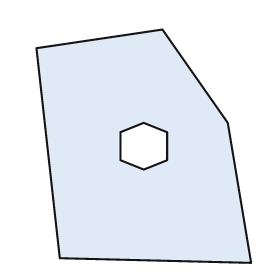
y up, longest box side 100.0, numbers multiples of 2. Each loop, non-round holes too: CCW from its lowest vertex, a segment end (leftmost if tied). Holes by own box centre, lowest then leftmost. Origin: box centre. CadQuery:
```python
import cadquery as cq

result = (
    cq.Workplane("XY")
    .moveTo(46.0, -50.0)
    .lineTo(36.0, 10.0)
    .lineTo(8.0, 50.0)
    .lineTo(-46.0, 42.0)
    .lineTo(-36.0, -48.0)
    .close()
    .moveTo(0.0, -10.0)
    .lineTo(10.0, -6.0)
    .lineTo(10.0, 6.0)
    .lineTo(0.0, 10.0)
    .lineTo(-10.0, 6.0)
    .lineTo(-10.0, -6.0)
    .close()
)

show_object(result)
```